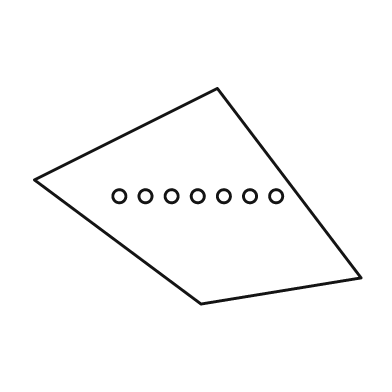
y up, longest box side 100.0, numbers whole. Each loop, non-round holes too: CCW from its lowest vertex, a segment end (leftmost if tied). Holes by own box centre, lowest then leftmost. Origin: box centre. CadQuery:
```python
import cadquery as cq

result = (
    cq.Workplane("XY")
    .moveTo(1.0, -33.0)
    .lineTo(50.0, -25.0)
    .lineTo(6.0, 33.0)
    .lineTo(-50.0, 5.0)
    .close()
    .moveTo(-24.0, 0.0)
    .circle(2.0)
    .moveTo(-16.0, 0.0)
    .circle(2.0)
    .moveTo(-8.0, 0.0)
    .circle(2.0)
    .moveTo(0.0, 0.0)
    .circle(2.0)
    .moveTo(8.0, 0.0)
    .circle(2.0)
    .moveTo(16.0, 0.0)
    .circle(2.0)
    .moveTo(24.0, 0.0)
    .circle(2.0)
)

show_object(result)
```